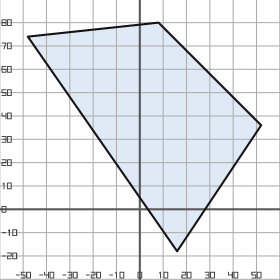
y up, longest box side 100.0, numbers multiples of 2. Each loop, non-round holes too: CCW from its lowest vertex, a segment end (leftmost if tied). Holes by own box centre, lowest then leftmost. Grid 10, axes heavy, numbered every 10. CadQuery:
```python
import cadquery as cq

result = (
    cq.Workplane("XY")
    .moveTo(16.0, -18.0)
    .lineTo(52.0, 36.0)
    .lineTo(8.0, 80.0)
    .lineTo(-48.0, 74.0)
    .close()
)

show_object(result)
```